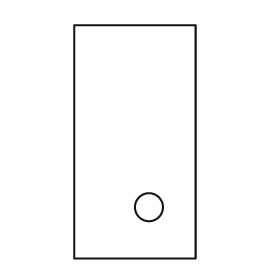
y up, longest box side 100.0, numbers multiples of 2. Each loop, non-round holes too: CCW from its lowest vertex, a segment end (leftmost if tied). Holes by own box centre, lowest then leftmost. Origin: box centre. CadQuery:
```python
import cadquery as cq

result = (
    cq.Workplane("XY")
    .moveTo(-26.0, -50.0)
    .lineTo(26.0, -50.0)
    .lineTo(26.0, 50.0)
    .lineTo(-26.0, 50.0)
    .close()
    .moveTo(6.0, -28.0)
    .circle(6.0)
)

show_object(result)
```